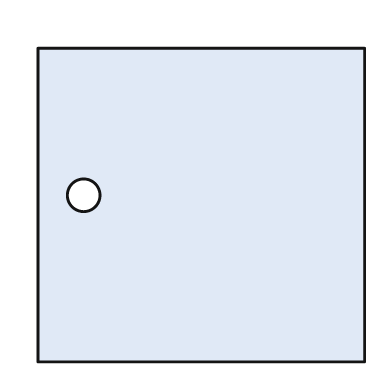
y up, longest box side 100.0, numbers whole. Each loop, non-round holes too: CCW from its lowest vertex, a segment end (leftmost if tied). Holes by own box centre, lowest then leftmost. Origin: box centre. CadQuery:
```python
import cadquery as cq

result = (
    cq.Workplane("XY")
    .moveTo(-50.0, -48.0)
    .lineTo(50.0, -48.0)
    .lineTo(50.0, 48.0)
    .lineTo(-50.0, 48.0)
    .close()
    .moveTo(-36.0, 3.0)
    .circle(5.0)
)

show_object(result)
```